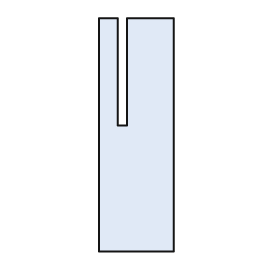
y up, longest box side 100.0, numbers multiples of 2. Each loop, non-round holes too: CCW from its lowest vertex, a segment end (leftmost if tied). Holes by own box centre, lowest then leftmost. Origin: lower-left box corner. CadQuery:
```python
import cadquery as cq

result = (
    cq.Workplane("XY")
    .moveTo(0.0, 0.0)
    .lineTo(32.0, 0.0)
    .lineTo(32.0, 100.0)
    .lineTo(12.0, 100.0)
    .lineTo(12.0, 54.0)
    .lineTo(8.0, 54.0)
    .lineTo(8.0, 100.0)
    .lineTo(0.0, 100.0)
    .close()
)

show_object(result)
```